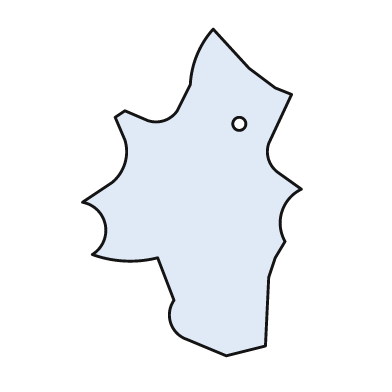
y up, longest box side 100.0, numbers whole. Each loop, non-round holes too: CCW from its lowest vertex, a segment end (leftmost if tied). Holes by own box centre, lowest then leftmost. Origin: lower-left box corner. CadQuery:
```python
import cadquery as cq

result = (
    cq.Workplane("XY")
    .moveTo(44.0, 0.0)
    .lineTo(56.0, 3.0)
    .lineTo(57.0, 24.0)
    .lineTo(59.0, 30.0)
    .lineTo(62.0, 35.0)
    .threePointArc((61.0, 44.0), (67.0, 51.0))
    .lineTo(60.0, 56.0)
    .threePointArc((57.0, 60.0), (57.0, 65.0))
    .lineTo(64.0, 80.0)
    .lineTo(59.0, 82.0)
    .lineTo(51.0, 88.0)
    .lineTo(40.0, 100.0)
    .threePointArc((35.0, 92.0), (33.0, 83.0))
    .lineTo(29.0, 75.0)
    .threePointArc((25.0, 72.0), (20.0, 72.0))
    .lineTo(13.0, 75.0)
    .lineTo(10.0, 73.0)
    .lineTo(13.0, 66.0)
    .threePointArc((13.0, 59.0), (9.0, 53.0))
    .lineTo(0.0, 47.0)
    .threePointArc((7.0, 40.0), (3.0, 31.0))
    .threePointArc((13.0, 29.0), (23.0, 30.0))
    .lineTo(28.0, 17.0)
    .threePointArc((27.0, 10.0), (32.0, 5.0))
    .close()
    .moveTo(48.0, 71.0)
    .circle(2.0)
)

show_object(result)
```